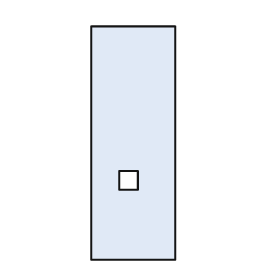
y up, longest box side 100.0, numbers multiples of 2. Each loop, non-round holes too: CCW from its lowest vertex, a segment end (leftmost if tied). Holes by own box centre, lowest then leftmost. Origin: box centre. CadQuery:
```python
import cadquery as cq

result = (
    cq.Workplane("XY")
    .moveTo(-18.0, -50.0)
    .lineTo(18.0, -50.0)
    .lineTo(18.0, 50.0)
    .lineTo(-18.0, 50.0)
    .close()
    .moveTo(-6.0, -20.0)
    .lineTo(2.0, -20.0)
    .lineTo(2.0, -12.0)
    .lineTo(-6.0, -12.0)
    .close()
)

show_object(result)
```